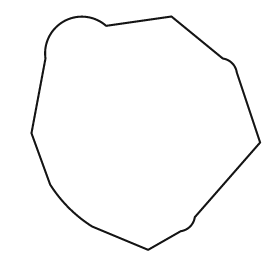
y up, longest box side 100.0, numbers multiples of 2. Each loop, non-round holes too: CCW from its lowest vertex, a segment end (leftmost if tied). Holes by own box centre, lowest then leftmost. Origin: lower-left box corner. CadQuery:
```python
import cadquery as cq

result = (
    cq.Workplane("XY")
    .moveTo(50.0, 0.0)
    .lineTo(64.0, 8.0)
    .threePointArc((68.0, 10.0), (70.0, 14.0))
    .lineTo(98.0, 46.0)
    .lineTo(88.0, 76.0)
    .threePointArc((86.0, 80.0), (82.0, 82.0))
    .lineTo(60.0, 100.0)
    .lineTo(32.0, 96.0)
    .threePointArc((14.0, 98.0), (6.0, 82.0))
    .lineTo(0.0, 50.0)
    .lineTo(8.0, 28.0)
    .threePointArc((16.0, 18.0), (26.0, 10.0))
    .close()
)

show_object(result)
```